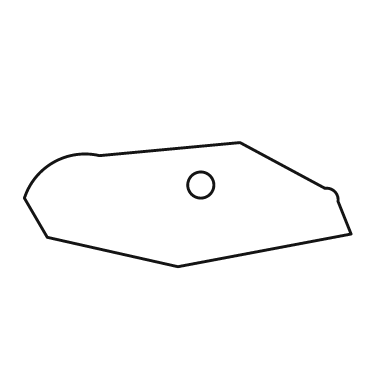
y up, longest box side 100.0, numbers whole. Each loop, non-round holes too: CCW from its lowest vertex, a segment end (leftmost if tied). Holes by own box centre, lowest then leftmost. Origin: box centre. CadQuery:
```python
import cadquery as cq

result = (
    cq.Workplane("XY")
    .moveTo(-3.0, -19.0)
    .lineTo(50.0, -9.0)
    .lineTo(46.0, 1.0)
    .threePointArc((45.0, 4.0), (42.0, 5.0))
    .lineTo(16.0, 19.0)
    .lineTo(-27.0, 15.0)
    .threePointArc((-41.0, 13.0), (-50.0, 2.0))
    .lineTo(-43.0, -10.0)
    .close()
    .moveTo(4.0, 6.0)
    .circle(4.0)
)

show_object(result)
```